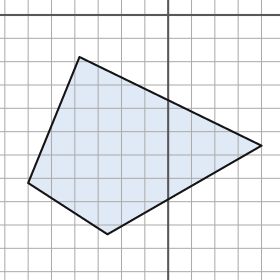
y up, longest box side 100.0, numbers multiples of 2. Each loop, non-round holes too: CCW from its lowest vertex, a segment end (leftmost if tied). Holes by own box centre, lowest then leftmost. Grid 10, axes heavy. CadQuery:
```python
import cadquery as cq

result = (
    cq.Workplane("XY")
    .moveTo(-26.0, -94.0)
    .lineTo(40.0, -56.0)
    .lineTo(-38.0, -18.0)
    .lineTo(-60.0, -72.0)
    .close()
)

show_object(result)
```